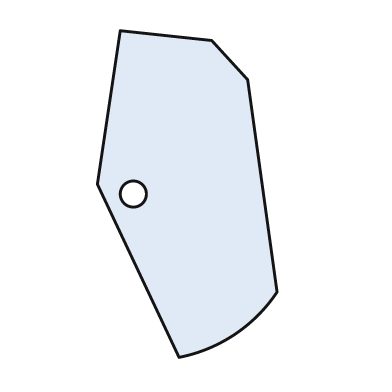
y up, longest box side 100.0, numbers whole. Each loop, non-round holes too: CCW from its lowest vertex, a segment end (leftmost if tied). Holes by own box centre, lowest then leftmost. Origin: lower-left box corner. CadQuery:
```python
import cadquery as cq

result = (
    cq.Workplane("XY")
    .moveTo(25.0, 0.0)
    .threePointArc((42.0, 7.0), (55.0, 20.0))
    .lineTo(46.0, 85.0)
    .lineTo(35.0, 97.0)
    .lineTo(7.0, 100.0)
    .lineTo(0.0, 53.0)
    .close()
    .moveTo(11.0, 50.0)
    .circle(4.0)
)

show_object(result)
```